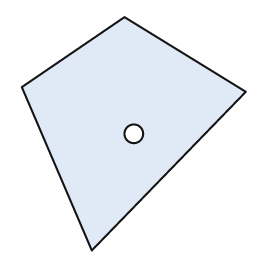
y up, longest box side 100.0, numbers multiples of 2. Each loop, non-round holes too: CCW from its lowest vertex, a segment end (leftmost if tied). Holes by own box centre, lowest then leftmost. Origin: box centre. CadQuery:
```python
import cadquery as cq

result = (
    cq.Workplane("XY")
    .moveTo(-18.0, -50.0)
    .lineTo(48.0, 18.0)
    .lineTo(-4.0, 50.0)
    .lineTo(-48.0, 20.0)
    .close()
    .moveTo(0.0, 0.0)
    .circle(4.0)
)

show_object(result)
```